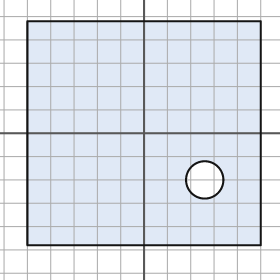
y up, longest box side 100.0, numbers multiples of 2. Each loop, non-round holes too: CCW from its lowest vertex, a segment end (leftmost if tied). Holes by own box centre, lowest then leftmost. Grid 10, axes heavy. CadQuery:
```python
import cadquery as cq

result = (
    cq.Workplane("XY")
    .moveTo(-50.0, -48.0)
    .lineTo(50.0, -48.0)
    .lineTo(50.0, 48.0)
    .lineTo(-50.0, 48.0)
    .close()
    .moveTo(26.0, -20.0)
    .circle(8.0)
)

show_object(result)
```